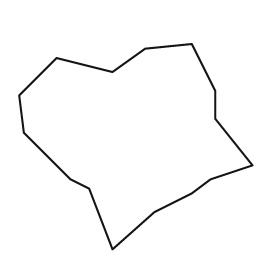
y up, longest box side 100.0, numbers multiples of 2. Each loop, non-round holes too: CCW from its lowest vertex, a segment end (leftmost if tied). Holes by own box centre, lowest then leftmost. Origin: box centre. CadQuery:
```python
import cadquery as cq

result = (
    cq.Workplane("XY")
    .moveTo(-10.0, -44.0)
    .lineTo(8.0, -28.0)
    .lineTo(24.0, -20.0)
    .lineTo(32.0, -14.0)
    .lineTo(50.0, -8.0)
    .lineTo(34.0, 12.0)
    .lineTo(34.0, 24.0)
    .lineTo(24.0, 44.0)
    .lineTo(4.0, 42.0)
    .lineTo(-10.0, 32.0)
    .lineTo(-34.0, 38.0)
    .lineTo(-50.0, 22.0)
    .lineTo(-48.0, 6.0)
    .lineTo(-28.0, -14.0)
    .lineTo(-20.0, -18.0)
    .close()
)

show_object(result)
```